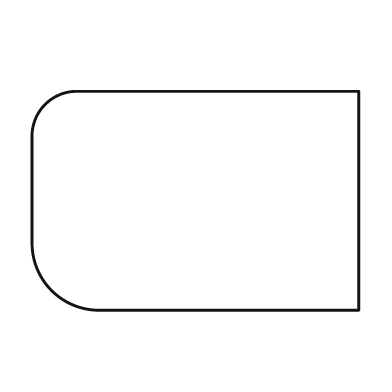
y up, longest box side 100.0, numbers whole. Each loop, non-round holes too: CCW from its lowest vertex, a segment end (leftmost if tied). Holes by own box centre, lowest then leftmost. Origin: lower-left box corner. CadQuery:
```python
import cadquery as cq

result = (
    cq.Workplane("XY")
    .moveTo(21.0, 0.0)
    .lineTo(100.0, 0.0)
    .lineTo(100.0, 67.0)
    .lineTo(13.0, 67.0)
    .threePointArc((4.0, 63.0), (0.0, 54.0))
    .lineTo(0.0, 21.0)
    .threePointArc((6.0, 6.0), (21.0, 0.0))
    .close()
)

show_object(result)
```